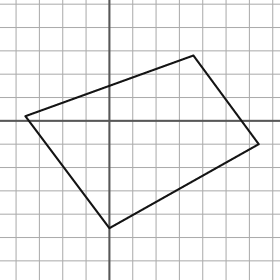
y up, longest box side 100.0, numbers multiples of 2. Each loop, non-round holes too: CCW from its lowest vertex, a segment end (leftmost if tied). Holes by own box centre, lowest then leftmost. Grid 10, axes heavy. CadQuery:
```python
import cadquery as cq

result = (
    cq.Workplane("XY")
    .moveTo(0.0, -46.0)
    .lineTo(64.0, -10.0)
    .lineTo(36.0, 28.0)
    .lineTo(-36.0, 2.0)
    .close()
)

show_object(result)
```